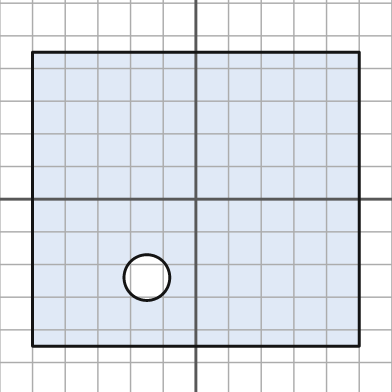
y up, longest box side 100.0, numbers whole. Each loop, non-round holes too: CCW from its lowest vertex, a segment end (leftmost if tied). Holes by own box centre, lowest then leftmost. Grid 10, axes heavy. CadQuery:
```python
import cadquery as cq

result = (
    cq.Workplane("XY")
    .moveTo(-50.0, -45.0)
    .lineTo(50.0, -45.0)
    .lineTo(50.0, 45.0)
    .lineTo(-50.0, 45.0)
    .close()
    .moveTo(-15.0, -24.0)
    .circle(7.0)
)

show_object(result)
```